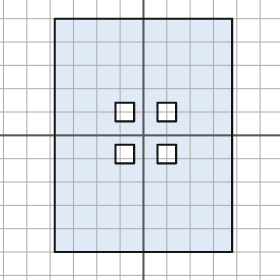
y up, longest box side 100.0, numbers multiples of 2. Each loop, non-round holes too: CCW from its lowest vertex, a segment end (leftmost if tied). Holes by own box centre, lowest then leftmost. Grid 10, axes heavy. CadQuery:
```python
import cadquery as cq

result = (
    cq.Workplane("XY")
    .moveTo(-38.0, -50.0)
    .lineTo(38.0, -50.0)
    .lineTo(38.0, 50.0)
    .lineTo(-38.0, 50.0)
    .close()
    .moveTo(-12.0, -12.0)
    .lineTo(-4.0, -12.0)
    .lineTo(-4.0, -4.0)
    .lineTo(-12.0, -4.0)
    .close()
    .moveTo(6.0, -12.0)
    .lineTo(14.0, -12.0)
    .lineTo(14.0, -4.0)
    .lineTo(6.0, -4.0)
    .close()
    .moveTo(-12.0, 6.0)
    .lineTo(-4.0, 6.0)
    .lineTo(-4.0, 14.0)
    .lineTo(-12.0, 14.0)
    .close()
    .moveTo(6.0, 6.0)
    .lineTo(14.0, 6.0)
    .lineTo(14.0, 14.0)
    .lineTo(6.0, 14.0)
    .close()
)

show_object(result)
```